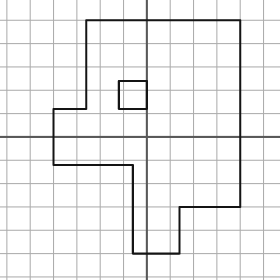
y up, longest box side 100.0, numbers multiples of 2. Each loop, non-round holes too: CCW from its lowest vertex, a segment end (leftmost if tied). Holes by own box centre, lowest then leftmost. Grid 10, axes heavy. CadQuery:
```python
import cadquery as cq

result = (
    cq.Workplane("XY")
    .moveTo(-6.0, -50.0)
    .lineTo(14.0, -50.0)
    .lineTo(14.0, -30.0)
    .lineTo(40.0, -30.0)
    .lineTo(40.0, 50.0)
    .lineTo(-26.0, 50.0)
    .lineTo(-26.0, 12.0)
    .lineTo(-40.0, 12.0)
    .lineTo(-40.0, -12.0)
    .lineTo(-6.0, -12.0)
    .close()
    .moveTo(-12.0, 12.0)
    .lineTo(0.0, 12.0)
    .lineTo(0.0, 24.0)
    .lineTo(-12.0, 24.0)
    .close()
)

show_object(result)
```